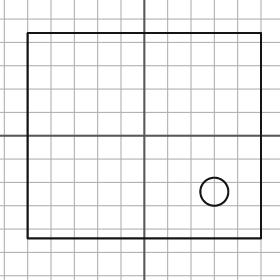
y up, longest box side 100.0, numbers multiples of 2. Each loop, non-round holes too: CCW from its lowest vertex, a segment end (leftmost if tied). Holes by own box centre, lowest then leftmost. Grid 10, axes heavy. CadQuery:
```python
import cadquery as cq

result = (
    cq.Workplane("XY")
    .moveTo(-50.0, -44.0)
    .lineTo(50.0, -44.0)
    .lineTo(50.0, 44.0)
    .lineTo(-50.0, 44.0)
    .close()
    .moveTo(30.0, -24.0)
    .circle(6.0)
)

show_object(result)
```